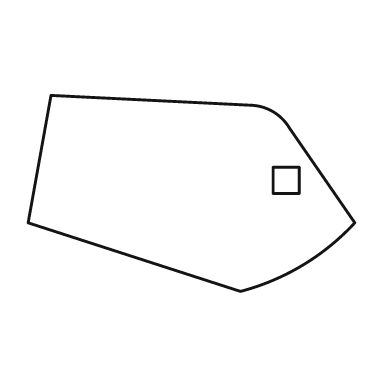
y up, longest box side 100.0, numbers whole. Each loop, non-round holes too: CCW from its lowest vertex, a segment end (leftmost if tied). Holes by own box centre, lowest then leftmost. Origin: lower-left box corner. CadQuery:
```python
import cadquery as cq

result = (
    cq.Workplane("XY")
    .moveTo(65.0, 0.0)
    .threePointArc((84.0, 8.0), (100.0, 21.0))
    .lineTo(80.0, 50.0)
    .threePointArc((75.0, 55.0), (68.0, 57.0))
    .lineTo(7.0, 60.0)
    .lineTo(0.0, 21.0)
    .close()
    .moveTo(75.0, 30.0)
    .lineTo(83.0, 30.0)
    .lineTo(83.0, 38.0)
    .lineTo(75.0, 38.0)
    .close()
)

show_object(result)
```